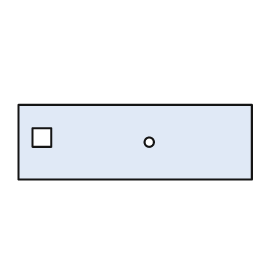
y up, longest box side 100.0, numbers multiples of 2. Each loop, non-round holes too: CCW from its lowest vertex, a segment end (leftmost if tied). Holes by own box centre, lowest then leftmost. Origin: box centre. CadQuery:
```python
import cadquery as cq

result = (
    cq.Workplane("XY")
    .moveTo(-50.0, -16.0)
    .lineTo(50.0, -16.0)
    .lineTo(50.0, 16.0)
    .lineTo(-50.0, 16.0)
    .close()
    .moveTo(6.0, 0.0)
    .circle(2.0)
    .moveTo(-44.0, -2.0)
    .lineTo(-36.0, -2.0)
    .lineTo(-36.0, 6.0)
    .lineTo(-44.0, 6.0)
    .close()
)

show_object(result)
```